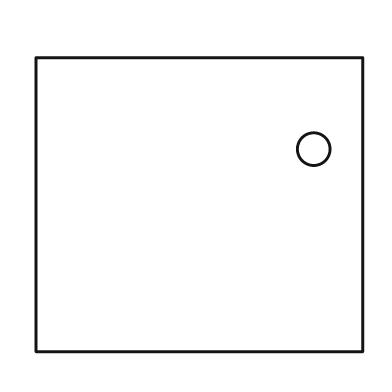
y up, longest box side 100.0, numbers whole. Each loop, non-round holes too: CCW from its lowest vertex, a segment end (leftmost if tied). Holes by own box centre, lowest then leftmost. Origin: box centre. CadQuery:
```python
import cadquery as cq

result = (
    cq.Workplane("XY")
    .moveTo(-50.0, -45.0)
    .lineTo(50.0, -45.0)
    .lineTo(50.0, 45.0)
    .lineTo(-50.0, 45.0)
    .close()
    .moveTo(35.0, 17.0)
    .circle(5.0)
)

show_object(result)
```